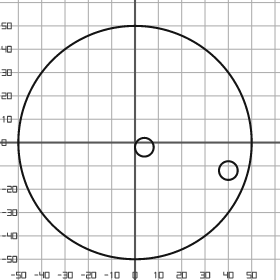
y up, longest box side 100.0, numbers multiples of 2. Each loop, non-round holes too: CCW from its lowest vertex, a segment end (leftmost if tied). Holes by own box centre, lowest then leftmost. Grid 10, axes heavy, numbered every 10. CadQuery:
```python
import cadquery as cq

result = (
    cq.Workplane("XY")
    .moveTo(0.0, 0.0)
    .circle(50.0)
    .moveTo(40.0, -12.0)
    .circle(4.0)
    .moveTo(4.0, -2.0)
    .circle(4.0)
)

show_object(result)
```